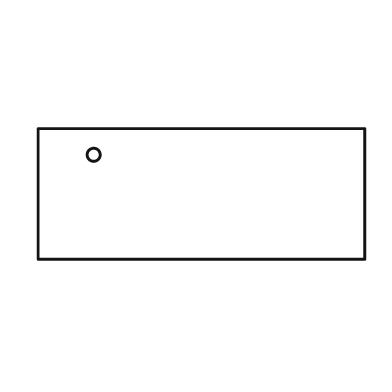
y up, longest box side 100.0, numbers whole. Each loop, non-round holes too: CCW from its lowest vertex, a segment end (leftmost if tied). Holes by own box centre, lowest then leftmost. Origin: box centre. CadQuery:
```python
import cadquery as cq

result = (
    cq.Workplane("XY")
    .moveTo(-50.0, -20.0)
    .lineTo(50.0, -20.0)
    .lineTo(50.0, 20.0)
    .lineTo(-50.0, 20.0)
    .close()
    .moveTo(-33.0, 12.0)
    .circle(2.0)
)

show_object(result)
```